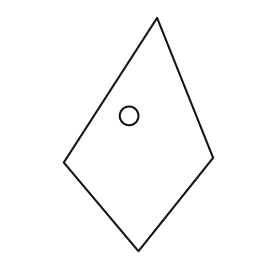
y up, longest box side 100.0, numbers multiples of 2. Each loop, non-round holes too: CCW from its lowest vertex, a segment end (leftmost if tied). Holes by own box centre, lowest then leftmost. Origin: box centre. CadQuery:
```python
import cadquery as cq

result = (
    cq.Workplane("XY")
    .moveTo(0.0, -50.0)
    .lineTo(32.0, -10.0)
    .lineTo(8.0, 50.0)
    .lineTo(-32.0, -12.0)
    .close()
    .moveTo(-4.0, 8.0)
    .circle(4.0)
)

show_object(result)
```